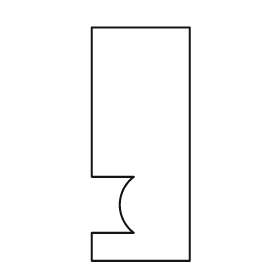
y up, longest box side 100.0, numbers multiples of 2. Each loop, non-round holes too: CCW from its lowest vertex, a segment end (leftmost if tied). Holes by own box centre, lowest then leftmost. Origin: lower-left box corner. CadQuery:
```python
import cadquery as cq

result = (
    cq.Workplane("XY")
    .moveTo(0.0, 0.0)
    .lineTo(42.0, 0.0)
    .lineTo(42.0, 100.0)
    .lineTo(0.0, 100.0)
    .lineTo(0.0, 36.0)
    .lineTo(18.0, 36.0)
    .threePointArc((12.0, 24.0), (18.0, 12.0))
    .lineTo(0.0, 12.0)
    .close()
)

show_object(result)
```